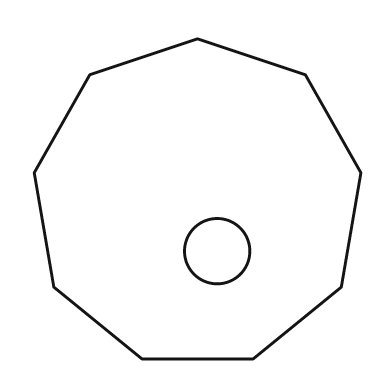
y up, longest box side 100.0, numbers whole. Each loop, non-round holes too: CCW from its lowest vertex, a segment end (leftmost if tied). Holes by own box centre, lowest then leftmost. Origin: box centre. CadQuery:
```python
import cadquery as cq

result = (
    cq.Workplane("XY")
    .moveTo(-17.0, -49.0)
    .lineTo(17.0, -49.0)
    .lineTo(44.0, -27.0)
    .lineTo(50.0, 8.0)
    .lineTo(33.0, 38.0)
    .lineTo(0.0, 49.0)
    .lineTo(-33.0, 38.0)
    .lineTo(-50.0, 8.0)
    .lineTo(-44.0, -27.0)
    .close()
    .moveTo(6.0, -16.0)
    .circle(10.0)
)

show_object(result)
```